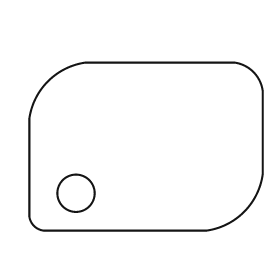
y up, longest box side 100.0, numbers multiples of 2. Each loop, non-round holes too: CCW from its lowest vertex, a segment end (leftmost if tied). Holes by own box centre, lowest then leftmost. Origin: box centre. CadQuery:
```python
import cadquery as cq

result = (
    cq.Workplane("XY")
    .moveTo(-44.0, -36.0)
    .lineTo(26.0, -36.0)
    .threePointArc((42.0, -28.0), (50.0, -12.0))
    .lineTo(50.0, 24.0)
    .threePointArc((46.0, 32.0), (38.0, 36.0))
    .lineTo(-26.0, 36.0)
    .threePointArc((-42.0, 28.0), (-50.0, 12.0))
    .lineTo(-50.0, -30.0)
    .threePointArc((-48.0, -34.0), (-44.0, -36.0))
    .close()
    .moveTo(-30.0, -20.0)
    .circle(8.0)
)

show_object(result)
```